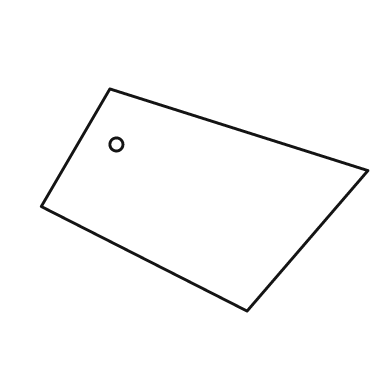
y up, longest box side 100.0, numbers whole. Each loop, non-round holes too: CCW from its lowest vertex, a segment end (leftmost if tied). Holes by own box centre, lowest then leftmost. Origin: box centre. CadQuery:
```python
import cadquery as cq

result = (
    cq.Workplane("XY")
    .moveTo(13.0, -34.0)
    .lineTo(50.0, 9.0)
    .lineTo(-29.0, 34.0)
    .lineTo(-50.0, -2.0)
    .close()
    .moveTo(-27.0, 17.0)
    .circle(2.0)
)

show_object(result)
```